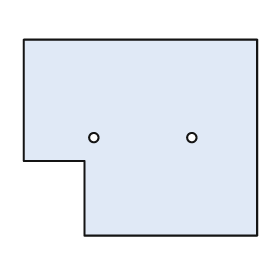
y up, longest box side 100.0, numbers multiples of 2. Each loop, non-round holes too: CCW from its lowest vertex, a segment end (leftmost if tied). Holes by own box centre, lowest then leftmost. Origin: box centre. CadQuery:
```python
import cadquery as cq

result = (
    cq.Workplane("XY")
    .moveTo(-24.0, -42.0)
    .lineTo(50.0, -42.0)
    .lineTo(50.0, 42.0)
    .lineTo(-50.0, 42.0)
    .lineTo(-50.0, -10.0)
    .lineTo(-24.0, -10.0)
    .close()
    .moveTo(-20.0, 0.0)
    .circle(2.0)
    .moveTo(22.0, 0.0)
    .circle(2.0)
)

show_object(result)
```